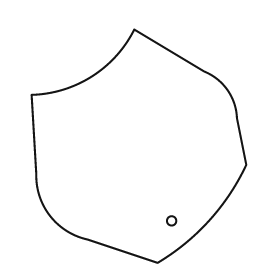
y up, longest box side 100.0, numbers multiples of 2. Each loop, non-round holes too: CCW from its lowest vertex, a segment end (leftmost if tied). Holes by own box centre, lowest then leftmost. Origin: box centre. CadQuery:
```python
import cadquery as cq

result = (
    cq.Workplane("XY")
    .moveTo(8.0, -50.0)
    .threePointArc((30.0, -32.0), (46.0, -8.0))
    .lineTo(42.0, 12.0)
    .threePointArc((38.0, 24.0), (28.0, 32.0))
    .lineTo(-2.0, 50.0)
    .threePointArc((-20.0, 30.0), (-46.0, 22.0))
    .lineTo(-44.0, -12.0)
    .threePointArc((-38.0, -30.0), (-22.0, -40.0))
    .close()
    .moveTo(14.0, -32.0)
    .circle(2.0)
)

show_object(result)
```